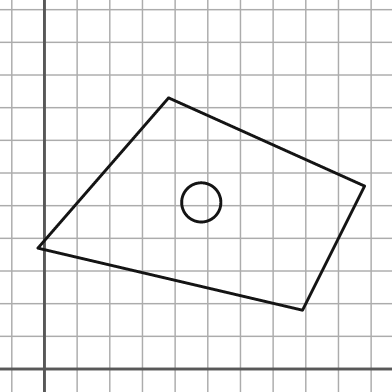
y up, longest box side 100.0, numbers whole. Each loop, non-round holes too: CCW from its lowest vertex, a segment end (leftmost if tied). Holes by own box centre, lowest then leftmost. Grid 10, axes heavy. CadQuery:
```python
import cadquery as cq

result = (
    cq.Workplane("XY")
    .moveTo(79.0, 18.0)
    .lineTo(98.0, 56.0)
    .lineTo(38.0, 83.0)
    .lineTo(-2.0, 37.0)
    .close()
    .moveTo(48.0, 51.0)
    .circle(6.0)
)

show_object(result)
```